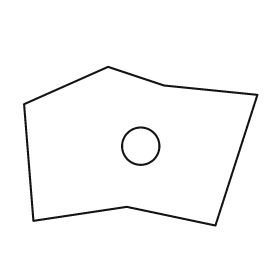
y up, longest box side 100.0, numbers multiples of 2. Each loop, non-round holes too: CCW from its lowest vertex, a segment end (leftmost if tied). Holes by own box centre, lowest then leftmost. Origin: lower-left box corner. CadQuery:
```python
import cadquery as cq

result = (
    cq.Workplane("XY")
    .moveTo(82.0, 0.0)
    .lineTo(100.0, 56.0)
    .lineTo(60.0, 60.0)
    .lineTo(36.0, 68.0)
    .lineTo(0.0, 52.0)
    .lineTo(4.0, 2.0)
    .lineTo(44.0, 8.0)
    .close()
    .moveTo(50.0, 34.0)
    .circle(8.0)
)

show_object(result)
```